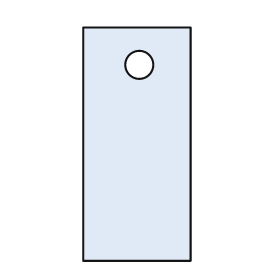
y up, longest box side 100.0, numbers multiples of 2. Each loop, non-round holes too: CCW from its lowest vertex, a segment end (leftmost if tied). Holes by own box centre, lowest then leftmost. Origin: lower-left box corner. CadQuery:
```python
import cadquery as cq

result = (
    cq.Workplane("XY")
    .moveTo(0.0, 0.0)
    .lineTo(46.0, 0.0)
    .lineTo(46.0, 100.0)
    .lineTo(0.0, 100.0)
    .close()
    .moveTo(24.0, 84.0)
    .circle(6.0)
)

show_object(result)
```